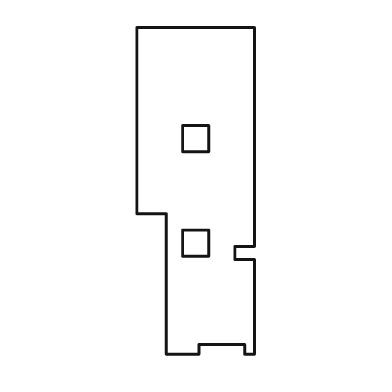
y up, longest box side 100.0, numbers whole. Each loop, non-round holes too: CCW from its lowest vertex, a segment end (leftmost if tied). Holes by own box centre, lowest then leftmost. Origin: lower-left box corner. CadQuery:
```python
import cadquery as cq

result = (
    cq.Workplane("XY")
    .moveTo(9.0, 0.0)
    .lineTo(19.0, 0.0)
    .lineTo(19.0, 3.0)
    .lineTo(33.0, 3.0)
    .lineTo(33.0, 0.0)
    .lineTo(36.0, 0.0)
    .lineTo(36.0, 29.0)
    .lineTo(30.0, 29.0)
    .lineTo(30.0, 33.0)
    .lineTo(36.0, 33.0)
    .lineTo(36.0, 100.0)
    .lineTo(0.0, 100.0)
    .lineTo(0.0, 43.0)
    .lineTo(9.0, 43.0)
    .close()
    .moveTo(14.0, 30.0)
    .lineTo(22.0, 30.0)
    .lineTo(22.0, 38.0)
    .lineTo(14.0, 38.0)
    .close()
    .moveTo(14.0, 62.0)
    .lineTo(22.0, 62.0)
    .lineTo(22.0, 70.0)
    .lineTo(14.0, 70.0)
    .close()
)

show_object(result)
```